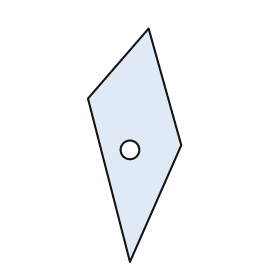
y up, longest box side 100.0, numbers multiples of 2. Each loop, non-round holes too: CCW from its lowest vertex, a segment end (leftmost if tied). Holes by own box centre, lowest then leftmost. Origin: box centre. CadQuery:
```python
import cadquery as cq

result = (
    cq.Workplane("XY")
    .moveTo(-2.0, -50.0)
    .lineTo(20.0, 0.0)
    .lineTo(6.0, 50.0)
    .lineTo(-20.0, 20.0)
    .close()
    .moveTo(-2.0, -2.0)
    .circle(4.0)
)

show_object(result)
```